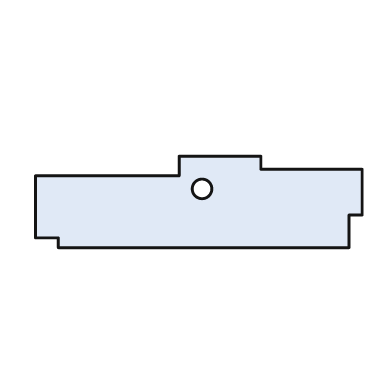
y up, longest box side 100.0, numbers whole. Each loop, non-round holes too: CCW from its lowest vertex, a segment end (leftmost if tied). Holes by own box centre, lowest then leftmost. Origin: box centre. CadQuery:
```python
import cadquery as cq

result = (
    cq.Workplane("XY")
    .moveTo(-43.0, -14.0)
    .lineTo(46.0, -14.0)
    .lineTo(46.0, -4.0)
    .lineTo(50.0, -4.0)
    .lineTo(50.0, 10.0)
    .lineTo(19.0, 10.0)
    .lineTo(19.0, 14.0)
    .lineTo(-6.0, 14.0)
    .lineTo(-6.0, 8.0)
    .lineTo(-50.0, 8.0)
    .lineTo(-50.0, -11.0)
    .lineTo(-43.0, -11.0)
    .close()
    .moveTo(1.0, 4.0)
    .circle(3.0)
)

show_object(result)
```